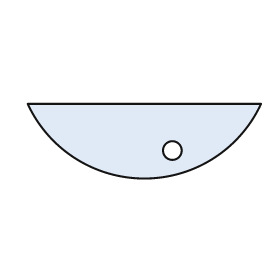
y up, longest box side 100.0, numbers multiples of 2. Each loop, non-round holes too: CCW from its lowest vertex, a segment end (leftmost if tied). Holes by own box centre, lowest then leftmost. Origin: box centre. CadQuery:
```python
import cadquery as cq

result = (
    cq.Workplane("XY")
    .moveTo(-50.0, 16.0)
    .threePointArc((0.0, -16.0), (50.0, 16.0))
    .close()
    .moveTo(12.0, -4.0)
    .circle(4.0)
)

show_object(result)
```